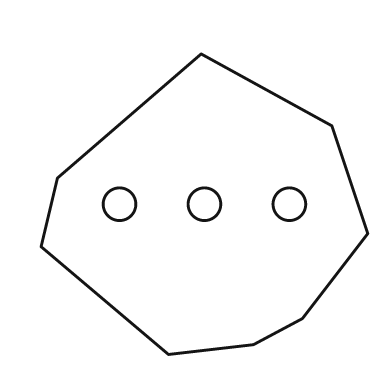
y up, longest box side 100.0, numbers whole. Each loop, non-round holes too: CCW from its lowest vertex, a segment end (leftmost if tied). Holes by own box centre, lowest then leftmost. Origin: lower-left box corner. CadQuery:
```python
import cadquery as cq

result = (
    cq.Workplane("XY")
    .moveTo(39.0, 0.0)
    .lineTo(65.0, 3.0)
    .lineTo(80.0, 11.0)
    .lineTo(100.0, 37.0)
    .lineTo(89.0, 70.0)
    .lineTo(49.0, 92.0)
    .lineTo(5.0, 54.0)
    .lineTo(0.0, 33.0)
    .close()
    .moveTo(24.0, 46.0)
    .circle(5.0)
    .moveTo(50.0, 46.0)
    .circle(5.0)
    .moveTo(76.0, 46.0)
    .circle(5.0)
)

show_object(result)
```